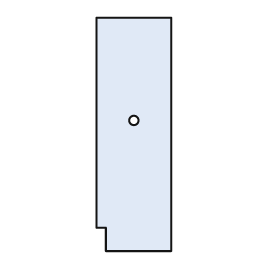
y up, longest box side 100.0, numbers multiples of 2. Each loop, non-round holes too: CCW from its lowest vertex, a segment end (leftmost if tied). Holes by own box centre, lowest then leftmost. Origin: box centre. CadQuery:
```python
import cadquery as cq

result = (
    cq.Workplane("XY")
    .moveTo(-12.0, -50.0)
    .lineTo(16.0, -50.0)
    .lineTo(16.0, 50.0)
    .lineTo(-16.0, 50.0)
    .lineTo(-16.0, -40.0)
    .lineTo(-12.0, -40.0)
    .close()
    .moveTo(0.0, 6.0)
    .circle(2.0)
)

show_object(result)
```